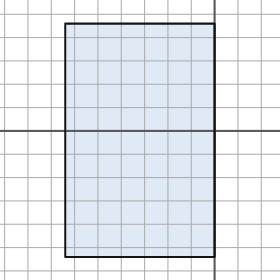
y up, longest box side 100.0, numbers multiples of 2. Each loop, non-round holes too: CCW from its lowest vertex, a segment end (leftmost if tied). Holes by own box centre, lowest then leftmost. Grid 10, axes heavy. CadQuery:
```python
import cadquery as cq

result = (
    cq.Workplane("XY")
    .moveTo(-64.0, -54.0)
    .lineTo(0.0, -54.0)
    .lineTo(0.0, 46.0)
    .lineTo(-64.0, 46.0)
    .close()
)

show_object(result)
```